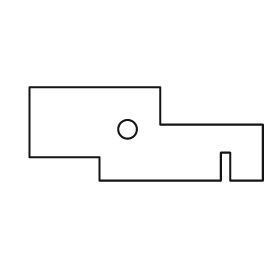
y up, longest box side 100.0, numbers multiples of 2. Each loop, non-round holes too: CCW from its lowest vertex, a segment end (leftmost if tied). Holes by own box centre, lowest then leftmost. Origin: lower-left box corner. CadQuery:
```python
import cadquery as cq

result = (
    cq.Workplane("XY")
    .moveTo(30.0, 0.0)
    .lineTo(82.0, 0.0)
    .lineTo(82.0, 12.0)
    .lineTo(86.0, 12.0)
    .lineTo(86.0, 0.0)
    .lineTo(100.0, 0.0)
    .lineTo(100.0, 24.0)
    .lineTo(56.0, 24.0)
    .lineTo(56.0, 40.0)
    .lineTo(0.0, 40.0)
    .lineTo(0.0, 10.0)
    .lineTo(30.0, 10.0)
    .close()
    .moveTo(42.0, 22.0)
    .circle(4.0)
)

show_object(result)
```